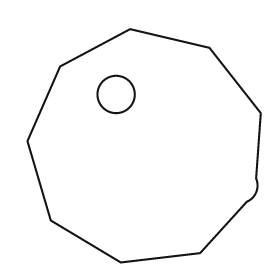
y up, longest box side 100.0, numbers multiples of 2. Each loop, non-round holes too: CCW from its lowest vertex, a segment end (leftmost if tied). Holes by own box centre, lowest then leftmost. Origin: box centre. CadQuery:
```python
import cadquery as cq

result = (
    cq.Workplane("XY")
    .moveTo(-10.0, -50.0)
    .lineTo(24.0, -46.0)
    .lineTo(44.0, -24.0)
    .threePointArc((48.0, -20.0), (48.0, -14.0))
    .lineTo(50.0, 14.0)
    .lineTo(28.0, 42.0)
    .lineTo(-6.0, 50.0)
    .lineTo(-36.0, 34.0)
    .lineTo(-50.0, 2.0)
    .lineTo(-40.0, -32.0)
    .close()
    .moveTo(-12.0, 22.0)
    .circle(8.0)
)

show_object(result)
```